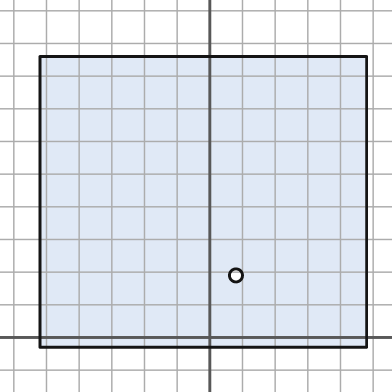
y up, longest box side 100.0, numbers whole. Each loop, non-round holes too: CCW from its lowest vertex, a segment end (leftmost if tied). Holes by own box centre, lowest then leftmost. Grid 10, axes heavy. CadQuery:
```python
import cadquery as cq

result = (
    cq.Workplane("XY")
    .moveTo(-52.0, -3.0)
    .lineTo(48.0, -3.0)
    .lineTo(48.0, 86.0)
    .lineTo(-52.0, 86.0)
    .close()
    .moveTo(8.0, 19.0)
    .circle(2.0)
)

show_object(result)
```